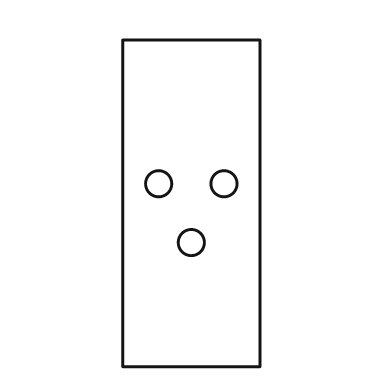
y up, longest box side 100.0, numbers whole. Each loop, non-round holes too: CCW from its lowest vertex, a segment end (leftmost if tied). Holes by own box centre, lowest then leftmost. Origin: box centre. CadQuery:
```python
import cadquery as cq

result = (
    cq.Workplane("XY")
    .moveTo(-21.0, -50.0)
    .lineTo(21.0, -50.0)
    .lineTo(21.0, 50.0)
    .lineTo(-21.0, 50.0)
    .close()
    .moveTo(0.0, -12.0)
    .circle(4.0)
    .moveTo(-10.0, 6.0)
    .circle(4.0)
    .moveTo(10.0, 6.0)
    .circle(4.0)
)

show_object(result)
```